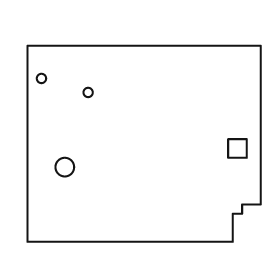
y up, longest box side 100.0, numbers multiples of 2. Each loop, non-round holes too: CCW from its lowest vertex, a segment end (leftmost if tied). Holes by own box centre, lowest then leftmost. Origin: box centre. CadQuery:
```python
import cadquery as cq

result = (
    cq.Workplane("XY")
    .moveTo(-50.0, -42.0)
    .lineTo(38.0, -42.0)
    .lineTo(38.0, -30.0)
    .lineTo(42.0, -30.0)
    .lineTo(42.0, -26.0)
    .lineTo(50.0, -26.0)
    .lineTo(50.0, 42.0)
    .lineTo(-50.0, 42.0)
    .close()
    .moveTo(-34.0, -10.0)
    .circle(4.0)
    .moveTo(36.0, -6.0)
    .lineTo(44.0, -6.0)
    .lineTo(44.0, 2.0)
    .lineTo(36.0, 2.0)
    .close()
    .moveTo(-24.0, 22.0)
    .circle(2.0)
    .moveTo(-44.0, 28.0)
    .circle(2.0)
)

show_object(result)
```